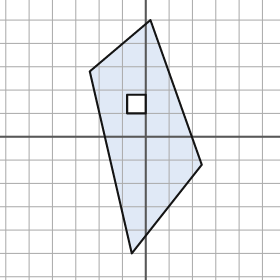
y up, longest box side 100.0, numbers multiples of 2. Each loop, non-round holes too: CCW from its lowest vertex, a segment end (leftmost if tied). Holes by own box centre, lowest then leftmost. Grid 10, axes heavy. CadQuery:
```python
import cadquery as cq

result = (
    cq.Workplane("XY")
    .moveTo(-6.0, -50.0)
    .lineTo(24.0, -12.0)
    .lineTo(2.0, 50.0)
    .lineTo(-24.0, 28.0)
    .close()
    .moveTo(-8.0, 10.0)
    .lineTo(0.0, 10.0)
    .lineTo(0.0, 18.0)
    .lineTo(-8.0, 18.0)
    .close()
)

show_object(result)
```